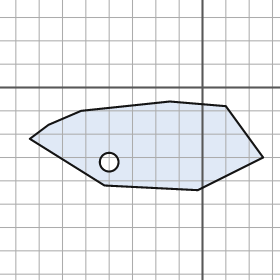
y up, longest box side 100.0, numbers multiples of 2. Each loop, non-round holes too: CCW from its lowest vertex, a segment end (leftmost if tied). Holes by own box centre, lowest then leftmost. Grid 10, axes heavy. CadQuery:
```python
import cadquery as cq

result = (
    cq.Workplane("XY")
    .moveTo(-2.0, -44.0)
    .lineTo(26.0, -30.0)
    .lineTo(10.0, -8.0)
    .lineTo(-14.0, -6.0)
    .lineTo(-52.0, -10.0)
    .lineTo(-66.0, -16.0)
    .lineTo(-74.0, -22.0)
    .lineTo(-42.0, -42.0)
    .close()
    .moveTo(-40.0, -32.0)
    .circle(4.0)
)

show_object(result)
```